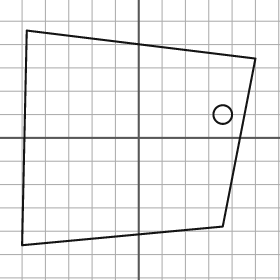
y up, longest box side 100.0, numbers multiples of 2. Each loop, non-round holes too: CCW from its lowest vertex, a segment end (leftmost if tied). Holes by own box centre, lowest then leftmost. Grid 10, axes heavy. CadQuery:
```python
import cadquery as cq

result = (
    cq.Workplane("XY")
    .moveTo(-50.0, -46.0)
    .lineTo(36.0, -38.0)
    .lineTo(50.0, 34.0)
    .lineTo(-48.0, 46.0)
    .close()
    .moveTo(36.0, 10.0)
    .circle(4.0)
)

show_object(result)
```